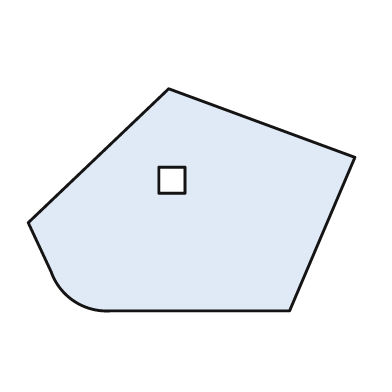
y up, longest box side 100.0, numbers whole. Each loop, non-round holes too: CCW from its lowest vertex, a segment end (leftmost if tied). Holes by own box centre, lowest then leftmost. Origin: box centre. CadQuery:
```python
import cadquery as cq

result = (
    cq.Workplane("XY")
    .moveTo(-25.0, -34.0)
    .lineTo(30.0, -34.0)
    .lineTo(50.0, 13.0)
    .lineTo(-7.0, 34.0)
    .lineTo(-50.0, -7.0)
    .lineTo(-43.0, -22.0)
    .threePointArc((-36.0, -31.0), (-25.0, -34.0))
    .close()
    .moveTo(-10.0, 2.0)
    .lineTo(-2.0, 2.0)
    .lineTo(-2.0, 10.0)
    .lineTo(-10.0, 10.0)
    .close()
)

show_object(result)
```